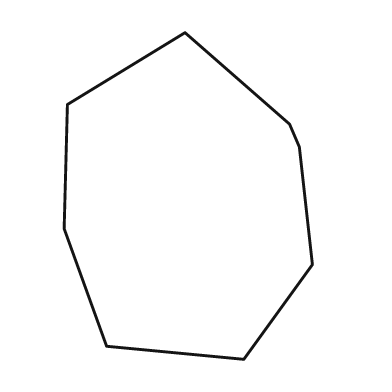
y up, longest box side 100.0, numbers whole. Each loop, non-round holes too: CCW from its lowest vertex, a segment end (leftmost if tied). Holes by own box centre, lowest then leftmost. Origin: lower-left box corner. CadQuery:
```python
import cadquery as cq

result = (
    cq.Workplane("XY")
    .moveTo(55.0, 0.0)
    .lineTo(76.0, 29.0)
    .lineTo(72.0, 65.0)
    .lineTo(69.0, 72.0)
    .lineTo(37.0, 100.0)
    .lineTo(1.0, 78.0)
    .lineTo(0.0, 40.0)
    .lineTo(13.0, 4.0)
    .close()
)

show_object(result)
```